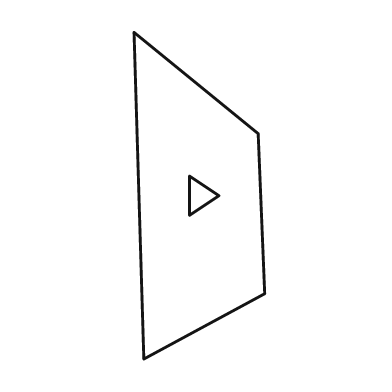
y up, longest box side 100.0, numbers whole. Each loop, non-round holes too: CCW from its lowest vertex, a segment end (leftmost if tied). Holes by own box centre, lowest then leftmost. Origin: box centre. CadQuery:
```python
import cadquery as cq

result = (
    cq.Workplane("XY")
    .moveTo(-17.0, -50.0)
    .lineTo(20.0, -30.0)
    .lineTo(18.0, 19.0)
    .lineTo(-20.0, 50.0)
    .close()
    .moveTo(-3.0, -6.0)
    .lineTo(6.0, 0.0)
    .lineTo(-3.0, 6.0)
    .close()
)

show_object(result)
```